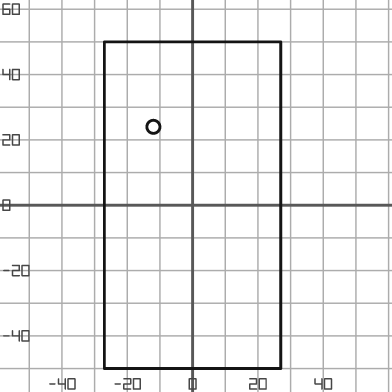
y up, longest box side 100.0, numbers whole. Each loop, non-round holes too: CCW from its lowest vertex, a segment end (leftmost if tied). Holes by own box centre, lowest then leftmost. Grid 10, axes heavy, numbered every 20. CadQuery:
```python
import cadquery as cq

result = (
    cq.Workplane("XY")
    .moveTo(-27.0, -50.0)
    .lineTo(27.0, -50.0)
    .lineTo(27.0, 50.0)
    .lineTo(-27.0, 50.0)
    .close()
    .moveTo(-12.0, 24.0)
    .circle(2.0)
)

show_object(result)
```